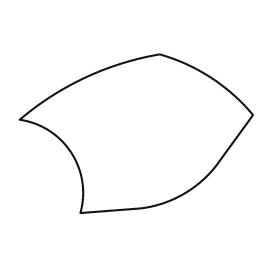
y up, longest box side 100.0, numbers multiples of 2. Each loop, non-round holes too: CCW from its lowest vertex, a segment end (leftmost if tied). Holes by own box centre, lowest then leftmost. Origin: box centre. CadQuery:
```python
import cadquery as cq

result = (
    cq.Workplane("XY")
    .moveTo(-24.0, -34.0)
    .lineTo(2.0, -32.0)
    .threePointArc((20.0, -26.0), (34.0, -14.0))
    .lineTo(50.0, 8.0)
    .threePointArc((32.0, 24.0), (10.0, 34.0))
    .threePointArc((-22.0, 24.0), (-50.0, 6.0))
    .threePointArc((-28.0, -8.0), (-24.0, -34.0))
    .close()
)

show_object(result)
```